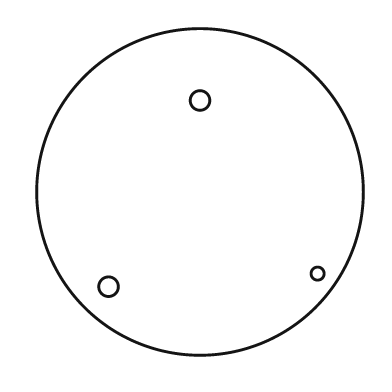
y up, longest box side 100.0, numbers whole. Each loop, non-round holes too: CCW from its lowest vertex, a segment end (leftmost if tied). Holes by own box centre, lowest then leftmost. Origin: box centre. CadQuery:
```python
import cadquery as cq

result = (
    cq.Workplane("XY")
    .moveTo(0.0, 0.0)
    .circle(50.0)
    .moveTo(-28.0, -29.0)
    .circle(3.0)
    .moveTo(36.0, -25.0)
    .circle(2.0)
    .moveTo(0.0, 28.0)
    .circle(3.0)
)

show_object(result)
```